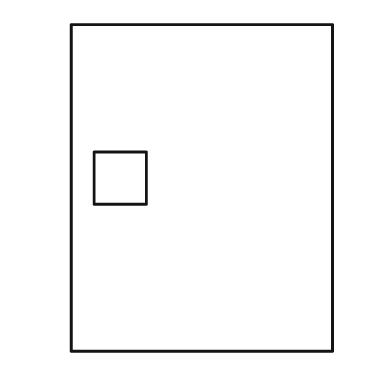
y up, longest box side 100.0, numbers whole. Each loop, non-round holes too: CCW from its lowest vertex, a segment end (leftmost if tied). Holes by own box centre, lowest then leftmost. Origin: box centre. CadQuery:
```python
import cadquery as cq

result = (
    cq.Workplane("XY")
    .moveTo(-40.0, -50.0)
    .lineTo(40.0, -50.0)
    .lineTo(40.0, 50.0)
    .lineTo(-40.0, 50.0)
    .close()
    .moveTo(-33.0, -5.0)
    .lineTo(-17.0, -5.0)
    .lineTo(-17.0, 11.0)
    .lineTo(-33.0, 11.0)
    .close()
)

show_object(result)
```